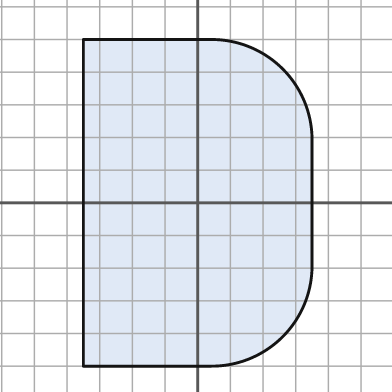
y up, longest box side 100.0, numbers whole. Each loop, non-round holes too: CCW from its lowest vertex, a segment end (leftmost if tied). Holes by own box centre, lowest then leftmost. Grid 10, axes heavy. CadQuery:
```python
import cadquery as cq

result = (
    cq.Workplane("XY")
    .moveTo(-35.0, -50.0)
    .lineTo(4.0, -50.0)
    .threePointArc((26.0, -41.0), (35.0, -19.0))
    .lineTo(35.0, 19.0)
    .threePointArc((26.0, 41.0), (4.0, 50.0))
    .lineTo(-35.0, 50.0)
    .close()
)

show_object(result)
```